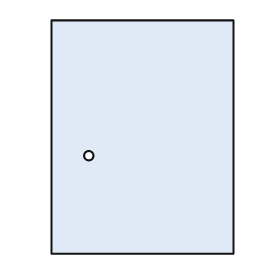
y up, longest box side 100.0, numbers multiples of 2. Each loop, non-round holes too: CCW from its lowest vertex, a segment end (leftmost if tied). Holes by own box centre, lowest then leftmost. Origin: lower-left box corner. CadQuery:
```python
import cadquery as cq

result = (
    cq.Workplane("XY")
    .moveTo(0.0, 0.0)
    .lineTo(78.0, 0.0)
    .lineTo(78.0, 100.0)
    .lineTo(0.0, 100.0)
    .close()
    .moveTo(16.0, 42.0)
    .circle(2.0)
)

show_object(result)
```